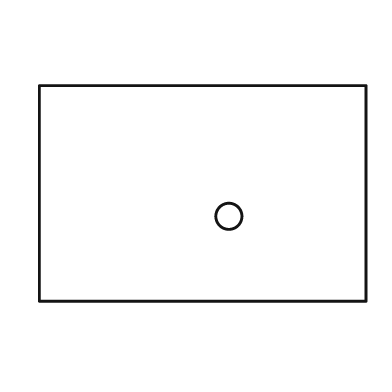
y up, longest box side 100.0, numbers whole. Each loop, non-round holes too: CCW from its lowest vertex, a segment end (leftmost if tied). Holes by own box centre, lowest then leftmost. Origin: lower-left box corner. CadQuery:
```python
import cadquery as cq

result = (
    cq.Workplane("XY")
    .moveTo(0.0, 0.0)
    .lineTo(100.0, 0.0)
    .lineTo(100.0, 66.0)
    .lineTo(0.0, 66.0)
    .close()
    .moveTo(58.0, 26.0)
    .circle(4.0)
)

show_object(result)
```